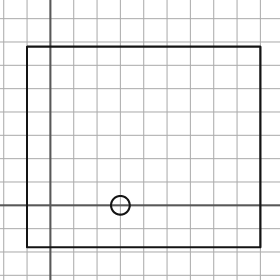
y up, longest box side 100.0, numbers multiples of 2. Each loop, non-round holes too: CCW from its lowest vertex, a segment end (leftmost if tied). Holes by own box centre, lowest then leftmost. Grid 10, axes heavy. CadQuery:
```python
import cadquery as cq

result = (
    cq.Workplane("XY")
    .moveTo(-10.0, -18.0)
    .lineTo(90.0, -18.0)
    .lineTo(90.0, 68.0)
    .lineTo(-10.0, 68.0)
    .close()
    .moveTo(30.0, 0.0)
    .circle(4.0)
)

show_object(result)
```